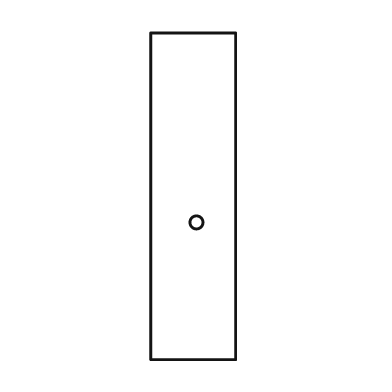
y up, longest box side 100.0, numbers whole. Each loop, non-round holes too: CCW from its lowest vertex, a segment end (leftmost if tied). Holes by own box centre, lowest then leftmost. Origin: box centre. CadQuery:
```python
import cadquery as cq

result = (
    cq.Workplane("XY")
    .moveTo(-13.0, -50.0)
    .lineTo(13.0, -50.0)
    .lineTo(13.0, 50.0)
    .lineTo(-13.0, 50.0)
    .close()
    .moveTo(1.0, -8.0)
    .circle(2.0)
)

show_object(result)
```